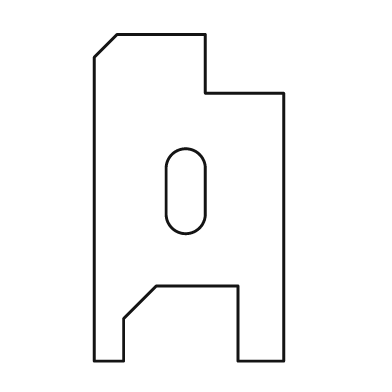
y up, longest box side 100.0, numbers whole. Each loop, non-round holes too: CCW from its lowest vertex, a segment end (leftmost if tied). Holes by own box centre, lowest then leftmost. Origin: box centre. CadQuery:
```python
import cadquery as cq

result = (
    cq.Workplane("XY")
    .moveTo(-29.0, -50.0)
    .lineTo(-20.0, -50.0)
    .lineTo(-20.0, -37.0)
    .lineTo(-10.0, -27.0)
    .lineTo(15.0, -27.0)
    .lineTo(15.0, -50.0)
    .lineTo(29.0, -50.0)
    .lineTo(29.0, 32.0)
    .lineTo(5.0, 32.0)
    .lineTo(5.0, 50.0)
    .lineTo(-22.0, 50.0)
    .lineTo(-29.0, 43.0)
    .close()
    .moveTo(-7.0, -5.0)
    .threePointArc((-1.0, -11.0), (5.0, -5.0))
    .lineTo(5.0, 9.0)
    .threePointArc((-1.0, 15.0), (-7.0, 9.0))
    .close()
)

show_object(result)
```